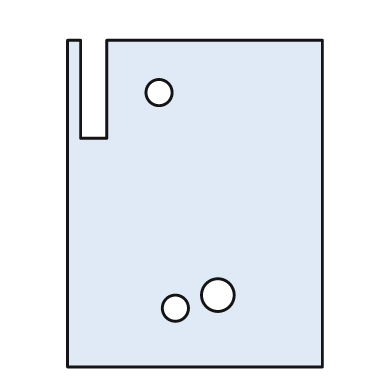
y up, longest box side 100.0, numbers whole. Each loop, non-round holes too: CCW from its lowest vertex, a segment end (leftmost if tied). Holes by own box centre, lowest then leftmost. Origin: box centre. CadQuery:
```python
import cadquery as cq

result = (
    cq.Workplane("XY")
    .moveTo(-39.0, -50.0)
    .lineTo(39.0, -50.0)
    .lineTo(39.0, 50.0)
    .lineTo(-27.0, 50.0)
    .lineTo(-27.0, 20.0)
    .lineTo(-35.0, 20.0)
    .lineTo(-35.0, 50.0)
    .lineTo(-39.0, 50.0)
    .close()
    .moveTo(-6.0, -32.0)
    .circle(4.0)
    .moveTo(7.0, -28.0)
    .circle(5.0)
    .moveTo(-11.0, 34.0)
    .circle(4.0)
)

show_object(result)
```